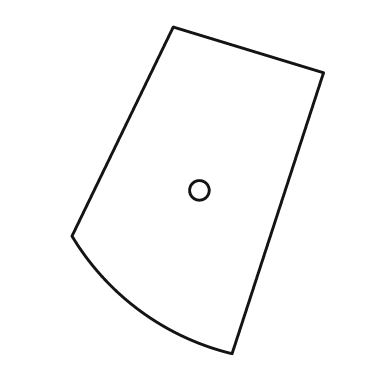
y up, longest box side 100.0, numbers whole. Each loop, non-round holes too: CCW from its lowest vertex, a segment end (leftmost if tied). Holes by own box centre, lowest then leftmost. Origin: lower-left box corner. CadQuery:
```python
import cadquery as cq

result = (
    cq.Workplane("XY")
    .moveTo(49.0, 0.0)
    .lineTo(77.0, 86.0)
    .lineTo(31.0, 100.0)
    .lineTo(0.0, 36.0)
    .threePointArc((21.0, 13.0), (49.0, 0.0))
    .close()
    .moveTo(39.0, 50.0)
    .circle(3.0)
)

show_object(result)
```